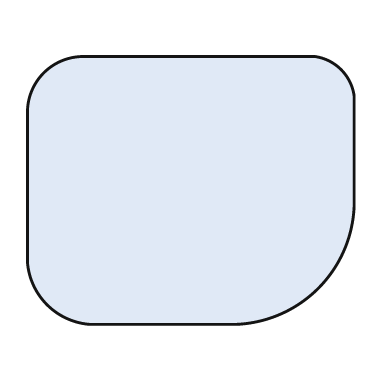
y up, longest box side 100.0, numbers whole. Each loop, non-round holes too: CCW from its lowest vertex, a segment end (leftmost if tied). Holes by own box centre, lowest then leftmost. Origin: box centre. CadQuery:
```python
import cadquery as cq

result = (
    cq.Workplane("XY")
    .moveTo(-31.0, -41.0)
    .lineTo(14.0, -41.0)
    .threePointArc((39.0, -30.0), (50.0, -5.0))
    .lineTo(50.0, 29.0)
    .threePointArc((46.0, 37.0), (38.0, 41.0))
    .lineTo(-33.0, 41.0)
    .threePointArc((-45.0, 36.0), (-50.0, 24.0))
    .lineTo(-50.0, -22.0)
    .threePointArc((-44.0, -35.0), (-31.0, -41.0))
    .close()
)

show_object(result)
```